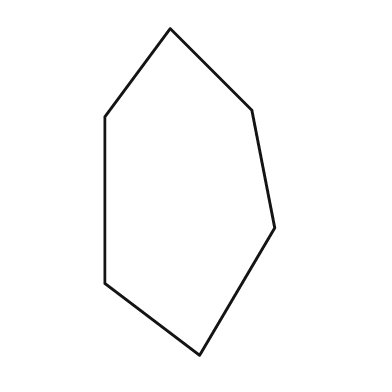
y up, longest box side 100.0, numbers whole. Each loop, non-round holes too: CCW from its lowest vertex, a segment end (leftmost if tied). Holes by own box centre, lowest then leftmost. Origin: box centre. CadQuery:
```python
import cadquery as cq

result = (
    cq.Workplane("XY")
    .moveTo(3.0, -50.0)
    .lineTo(26.0, -11.0)
    .lineTo(19.0, 25.0)
    .lineTo(-6.0, 50.0)
    .lineTo(-26.0, 23.0)
    .lineTo(-26.0, -28.0)
    .close()
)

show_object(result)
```